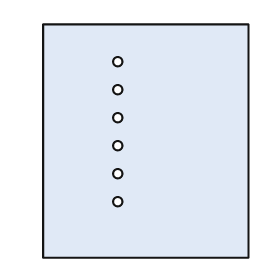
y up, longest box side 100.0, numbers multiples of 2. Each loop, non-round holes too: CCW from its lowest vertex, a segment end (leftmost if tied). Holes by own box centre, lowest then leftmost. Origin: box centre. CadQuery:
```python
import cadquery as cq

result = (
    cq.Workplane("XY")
    .moveTo(-44.0, -50.0)
    .lineTo(44.0, -50.0)
    .lineTo(44.0, 50.0)
    .lineTo(-44.0, 50.0)
    .close()
    .moveTo(-12.0, -26.0)
    .circle(2.0)
    .moveTo(-12.0, -14.0)
    .circle(2.0)
    .moveTo(-12.0, -2.0)
    .circle(2.0)
    .moveTo(-12.0, 10.0)
    .circle(2.0)
    .moveTo(-12.0, 22.0)
    .circle(2.0)
    .moveTo(-12.0, 34.0)
    .circle(2.0)
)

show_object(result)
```